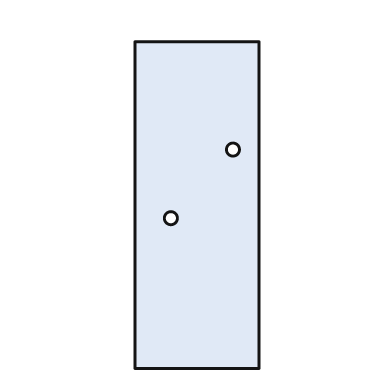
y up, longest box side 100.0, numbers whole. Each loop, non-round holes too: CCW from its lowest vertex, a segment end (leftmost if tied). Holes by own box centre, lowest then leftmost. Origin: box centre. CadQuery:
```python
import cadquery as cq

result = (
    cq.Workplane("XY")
    .moveTo(-19.0, -50.0)
    .lineTo(19.0, -50.0)
    .lineTo(19.0, 50.0)
    .lineTo(-19.0, 50.0)
    .close()
    .moveTo(-8.0, -4.0)
    .circle(2.0)
    .moveTo(11.0, 17.0)
    .circle(2.0)
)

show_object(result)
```